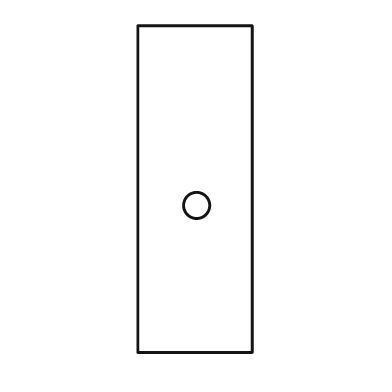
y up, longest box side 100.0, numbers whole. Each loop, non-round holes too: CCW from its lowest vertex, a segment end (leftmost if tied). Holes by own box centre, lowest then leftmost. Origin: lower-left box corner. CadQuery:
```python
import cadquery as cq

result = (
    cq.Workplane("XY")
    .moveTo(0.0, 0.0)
    .lineTo(35.0, 0.0)
    .lineTo(35.0, 100.0)
    .lineTo(0.0, 100.0)
    .close()
    .moveTo(18.0, 45.0)
    .circle(4.0)
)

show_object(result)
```